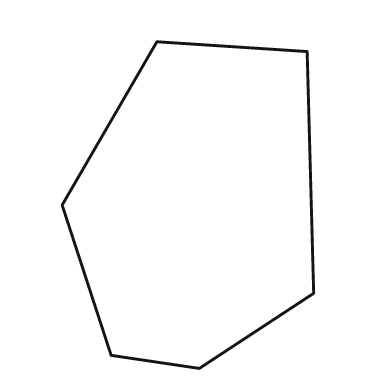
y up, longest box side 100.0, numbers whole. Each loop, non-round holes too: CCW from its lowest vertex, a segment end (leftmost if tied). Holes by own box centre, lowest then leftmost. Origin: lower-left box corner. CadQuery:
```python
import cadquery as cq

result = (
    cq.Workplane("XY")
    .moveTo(42.0, 0.0)
    .lineTo(77.0, 23.0)
    .lineTo(75.0, 97.0)
    .lineTo(29.0, 100.0)
    .lineTo(0.0, 50.0)
    .lineTo(15.0, 4.0)
    .close()
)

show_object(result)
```